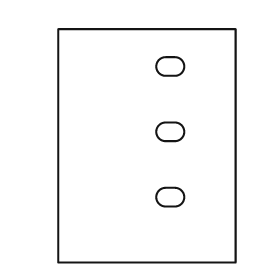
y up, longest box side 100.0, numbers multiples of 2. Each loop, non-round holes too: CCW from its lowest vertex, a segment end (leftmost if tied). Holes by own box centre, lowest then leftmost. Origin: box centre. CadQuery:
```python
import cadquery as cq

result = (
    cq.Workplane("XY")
    .moveTo(-38.0, -50.0)
    .lineTo(38.0, -50.0)
    .lineTo(38.0, 50.0)
    .lineTo(-38.0, 50.0)
    .close()
    .moveTo(8.0, -26.0)
    .lineTo(12.0, -26.0)
    .threePointArc((16.0, -22.0), (12.0, -18.0))
    .lineTo(8.0, -18.0)
    .threePointArc((4.0, -22.0), (8.0, -26.0))
    .close()
    .moveTo(8.0, 2.0)
    .lineTo(12.0, 2.0)
    .threePointArc((16.0, 6.0), (12.0, 10.0))
    .lineTo(8.0, 10.0)
    .threePointArc((4.0, 6.0), (8.0, 2.0))
    .close()
    .moveTo(8.0, 30.0)
    .lineTo(12.0, 30.0)
    .threePointArc((16.0, 34.0), (12.0, 38.0))
    .lineTo(8.0, 38.0)
    .threePointArc((4.0, 34.0), (8.0, 30.0))
    .close()
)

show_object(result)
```